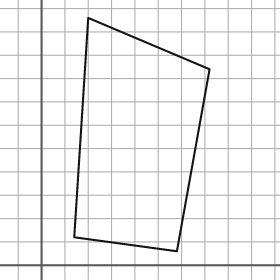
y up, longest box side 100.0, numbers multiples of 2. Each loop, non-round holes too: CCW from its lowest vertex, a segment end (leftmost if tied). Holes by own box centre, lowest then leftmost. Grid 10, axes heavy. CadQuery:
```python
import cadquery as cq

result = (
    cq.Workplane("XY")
    .moveTo(58.0, 6.0)
    .lineTo(72.0, 84.0)
    .lineTo(20.0, 106.0)
    .lineTo(14.0, 12.0)
    .close()
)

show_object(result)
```